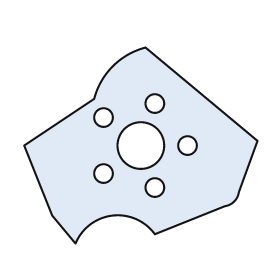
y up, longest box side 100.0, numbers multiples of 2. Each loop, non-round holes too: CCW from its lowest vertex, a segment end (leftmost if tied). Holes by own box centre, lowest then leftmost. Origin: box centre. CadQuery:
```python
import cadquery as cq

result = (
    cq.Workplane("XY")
    .moveTo(-28.0, -42.0)
    .threePointArc((-12.0, -30.0), (6.0, -38.0))
    .lineTo(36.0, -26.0)
    .threePointArc((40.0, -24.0), (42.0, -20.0))
    .lineTo(50.0, 2.0)
    .lineTo(2.0, 42.0)
    .threePointArc((-12.0, 34.0), (-20.0, 20.0))
    .lineTo(-50.0, 0.0)
    .lineTo(-38.0, -30.0)
    .close()
    .moveTo(6.0, -18.0)
    .circle(4.0)
    .moveTo(-16.0, -12.0)
    .circle(4.0)
    .moveTo(0.0, 0.0)
    .circle(10.0)
    .moveTo(20.0, 0.0)
    .circle(4.0)
    .moveTo(-16.0, 12.0)
    .circle(4.0)
    .moveTo(6.0, 18.0)
    .circle(4.0)
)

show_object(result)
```